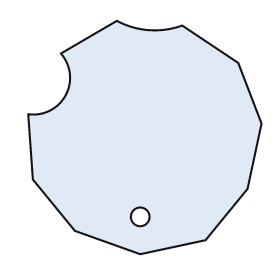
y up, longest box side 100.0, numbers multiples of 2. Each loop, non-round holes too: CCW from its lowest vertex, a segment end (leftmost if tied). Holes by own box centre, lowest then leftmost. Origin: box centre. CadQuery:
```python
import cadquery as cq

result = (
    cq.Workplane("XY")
    .moveTo(-2.0, -50.0)
    .lineTo(26.0, -44.0)
    .lineTo(44.0, -22.0)
    .lineTo(50.0, 6.0)
    .lineTo(40.0, 32.0)
    .lineTo(16.0, 48.0)
    .threePointArc((2.0, 46.0), (-12.0, 50.0))
    .lineTo(-36.0, 36.0)
    .threePointArc((-34.0, 18.0), (-50.0, 10.0))
    .lineTo(-48.0, -18.0)
    .lineTo(-30.0, -40.0)
    .close()
    .moveTo(-2.0, -34.0)
    .circle(4.0)
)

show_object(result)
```